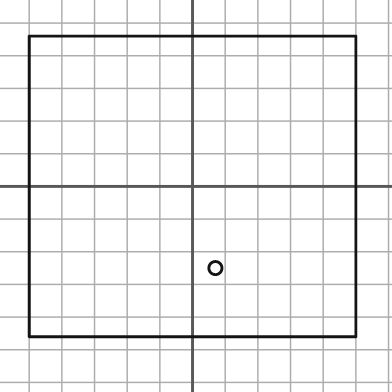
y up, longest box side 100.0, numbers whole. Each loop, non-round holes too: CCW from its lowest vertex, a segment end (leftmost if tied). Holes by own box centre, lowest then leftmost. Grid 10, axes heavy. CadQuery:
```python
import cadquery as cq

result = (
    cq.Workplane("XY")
    .moveTo(-50.0, -46.0)
    .lineTo(50.0, -46.0)
    .lineTo(50.0, 46.0)
    .lineTo(-50.0, 46.0)
    .close()
    .moveTo(7.0, -25.0)
    .circle(2.0)
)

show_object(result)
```